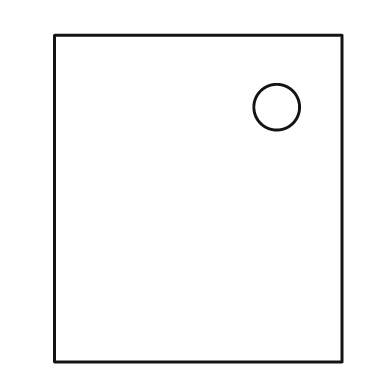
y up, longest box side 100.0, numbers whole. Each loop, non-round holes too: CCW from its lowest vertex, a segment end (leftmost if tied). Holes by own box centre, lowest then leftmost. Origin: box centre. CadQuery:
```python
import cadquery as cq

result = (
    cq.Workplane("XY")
    .moveTo(-44.0, -50.0)
    .lineTo(44.0, -50.0)
    .lineTo(44.0, 50.0)
    .lineTo(-44.0, 50.0)
    .close()
    .moveTo(24.0, 28.0)
    .circle(7.0)
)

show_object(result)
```